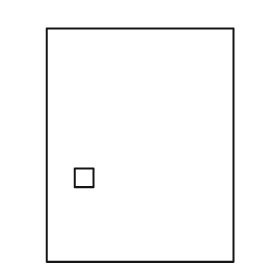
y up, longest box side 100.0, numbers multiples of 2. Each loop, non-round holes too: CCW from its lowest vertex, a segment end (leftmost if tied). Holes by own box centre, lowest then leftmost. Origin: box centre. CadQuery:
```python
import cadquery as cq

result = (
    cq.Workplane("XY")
    .moveTo(-40.0, -50.0)
    .lineTo(40.0, -50.0)
    .lineTo(40.0, 50.0)
    .lineTo(-40.0, 50.0)
    .close()
    .moveTo(-28.0, -18.0)
    .lineTo(-20.0, -18.0)
    .lineTo(-20.0, -10.0)
    .lineTo(-28.0, -10.0)
    .close()
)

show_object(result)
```